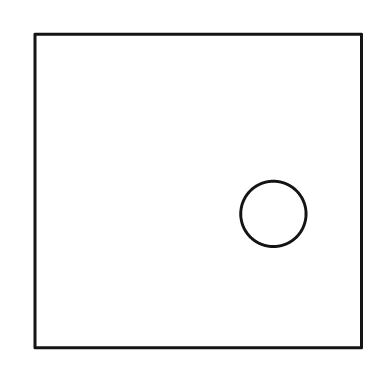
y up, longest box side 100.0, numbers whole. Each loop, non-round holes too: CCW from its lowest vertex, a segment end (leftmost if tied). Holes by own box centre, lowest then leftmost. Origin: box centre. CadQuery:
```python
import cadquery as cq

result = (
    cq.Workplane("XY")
    .moveTo(-50.0, -48.0)
    .lineTo(50.0, -48.0)
    .lineTo(50.0, 48.0)
    .lineTo(-50.0, 48.0)
    .close()
    .moveTo(23.0, -7.0)
    .circle(10.0)
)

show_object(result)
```